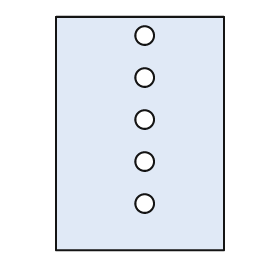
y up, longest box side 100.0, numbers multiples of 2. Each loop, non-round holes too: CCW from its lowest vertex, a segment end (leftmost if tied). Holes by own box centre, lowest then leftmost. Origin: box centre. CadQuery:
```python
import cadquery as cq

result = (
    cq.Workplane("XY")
    .moveTo(-36.0, -50.0)
    .lineTo(36.0, -50.0)
    .lineTo(36.0, 50.0)
    .lineTo(-36.0, 50.0)
    .close()
    .moveTo(2.0, -30.0)
    .circle(4.0)
    .moveTo(2.0, -12.0)
    .circle(4.0)
    .moveTo(2.0, 6.0)
    .circle(4.0)
    .moveTo(2.0, 24.0)
    .circle(4.0)
    .moveTo(2.0, 42.0)
    .circle(4.0)
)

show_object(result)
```